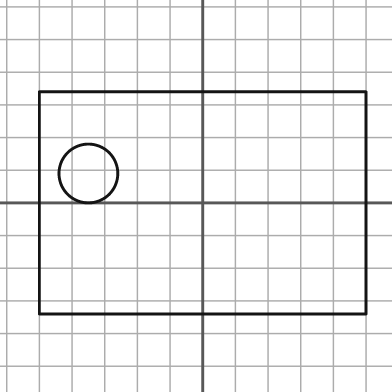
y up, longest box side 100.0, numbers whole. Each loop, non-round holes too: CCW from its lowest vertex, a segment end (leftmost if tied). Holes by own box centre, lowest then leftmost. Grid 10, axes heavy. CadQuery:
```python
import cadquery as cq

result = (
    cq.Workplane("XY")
    .moveTo(-50.0, -34.0)
    .lineTo(50.0, -34.0)
    .lineTo(50.0, 34.0)
    .lineTo(-50.0, 34.0)
    .close()
    .moveTo(-35.0, 9.0)
    .circle(9.0)
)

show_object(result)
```